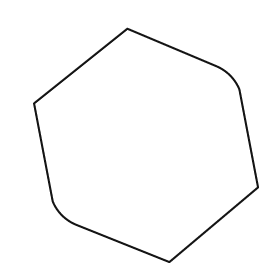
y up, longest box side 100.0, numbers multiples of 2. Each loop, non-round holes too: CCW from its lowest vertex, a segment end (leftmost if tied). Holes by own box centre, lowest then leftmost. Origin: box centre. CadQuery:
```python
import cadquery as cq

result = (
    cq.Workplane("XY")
    .moveTo(10.0, -50.0)
    .lineTo(48.0, -18.0)
    .lineTo(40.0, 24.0)
    .threePointArc((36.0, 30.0), (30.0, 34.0))
    .lineTo(-8.0, 50.0)
    .lineTo(-48.0, 18.0)
    .lineTo(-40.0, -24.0)
    .threePointArc((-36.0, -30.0), (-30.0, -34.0))
    .close()
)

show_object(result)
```